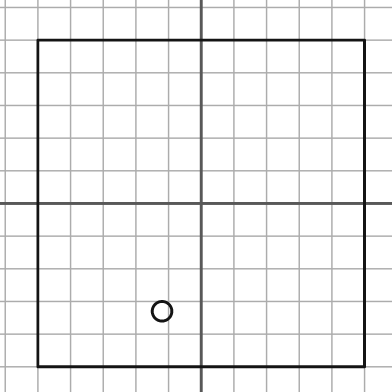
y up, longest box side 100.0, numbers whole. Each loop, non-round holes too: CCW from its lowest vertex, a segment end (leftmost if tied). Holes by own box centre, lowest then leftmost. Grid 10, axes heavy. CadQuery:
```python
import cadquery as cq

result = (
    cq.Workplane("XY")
    .moveTo(-50.0, -50.0)
    .lineTo(50.0, -50.0)
    .lineTo(50.0, 50.0)
    .lineTo(-50.0, 50.0)
    .close()
    .moveTo(-12.0, -33.0)
    .circle(3.0)
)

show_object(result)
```